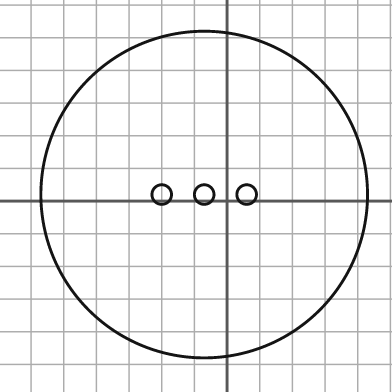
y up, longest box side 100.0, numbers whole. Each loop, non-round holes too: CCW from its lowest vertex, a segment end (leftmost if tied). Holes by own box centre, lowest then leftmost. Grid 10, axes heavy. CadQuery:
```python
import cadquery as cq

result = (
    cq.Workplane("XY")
    .moveTo(-7.0, 2.0)
    .circle(50.0)
    .moveTo(-20.0, 2.0)
    .circle(3.0)
    .moveTo(-7.0, 2.0)
    .circle(3.0)
    .moveTo(6.0, 2.0)
    .circle(3.0)
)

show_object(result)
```